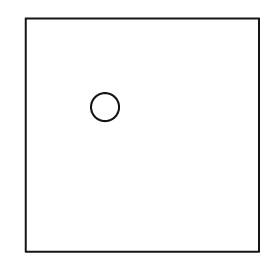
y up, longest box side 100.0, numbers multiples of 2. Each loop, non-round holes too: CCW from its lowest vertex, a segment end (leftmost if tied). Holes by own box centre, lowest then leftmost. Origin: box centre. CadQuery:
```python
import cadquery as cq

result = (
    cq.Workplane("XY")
    .moveTo(-50.0, -50.0)
    .lineTo(50.0, -50.0)
    .lineTo(50.0, 50.0)
    .lineTo(-50.0, 50.0)
    .close()
    .moveTo(-16.0, 12.0)
    .circle(6.0)
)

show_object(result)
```